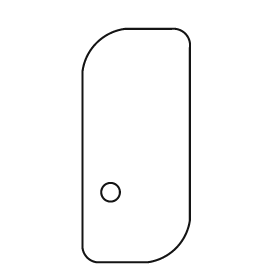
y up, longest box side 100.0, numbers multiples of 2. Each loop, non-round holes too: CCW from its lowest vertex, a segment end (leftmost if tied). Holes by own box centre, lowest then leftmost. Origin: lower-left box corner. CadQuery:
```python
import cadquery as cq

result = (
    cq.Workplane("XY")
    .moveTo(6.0, 0.0)
    .lineTo(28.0, 0.0)
    .threePointArc((40.0, 6.0), (46.0, 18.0))
    .lineTo(46.0, 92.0)
    .threePointArc((44.0, 98.0), (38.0, 100.0))
    .lineTo(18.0, 100.0)
    .threePointArc((6.0, 94.0), (0.0, 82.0))
    .lineTo(0.0, 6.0)
    .threePointArc((2.0, 2.0), (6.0, 0.0))
    .close()
    .moveTo(12.0, 30.0)
    .circle(4.0)
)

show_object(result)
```